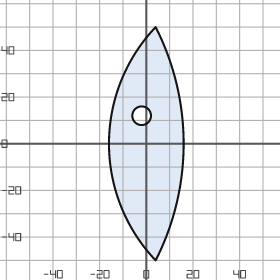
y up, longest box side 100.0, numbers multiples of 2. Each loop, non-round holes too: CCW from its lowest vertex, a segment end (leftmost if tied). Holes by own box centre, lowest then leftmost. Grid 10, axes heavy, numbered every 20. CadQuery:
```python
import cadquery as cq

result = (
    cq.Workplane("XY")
    .moveTo(4.0, -50.0)
    .threePointArc((16.0, 0.0), (4.0, 50.0))
    .threePointArc((-16.0, 0.0), (4.0, -50.0))
    .close()
    .moveTo(-2.0, 12.0)
    .circle(4.0)
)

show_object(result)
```